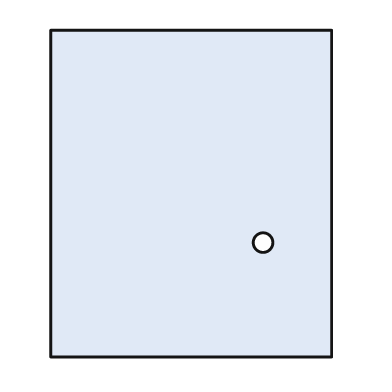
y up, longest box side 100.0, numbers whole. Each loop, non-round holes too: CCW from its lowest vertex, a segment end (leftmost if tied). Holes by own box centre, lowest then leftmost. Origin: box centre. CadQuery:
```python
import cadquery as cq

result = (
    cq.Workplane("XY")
    .moveTo(-43.0, -50.0)
    .lineTo(43.0, -50.0)
    .lineTo(43.0, 50.0)
    .lineTo(-43.0, 50.0)
    .close()
    .moveTo(22.0, -15.0)
    .circle(3.0)
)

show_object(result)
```